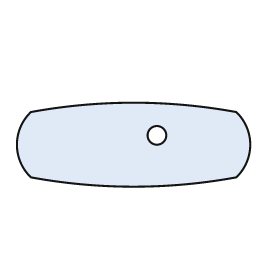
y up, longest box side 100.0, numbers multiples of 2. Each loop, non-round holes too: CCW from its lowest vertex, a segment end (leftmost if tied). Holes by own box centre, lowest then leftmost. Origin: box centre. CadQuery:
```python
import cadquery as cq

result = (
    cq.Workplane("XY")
    .moveTo(-44.0, -14.0)
    .threePointArc((0.0, -18.0), (44.0, -14.0))
    .threePointArc((50.0, 0.0), (44.0, 14.0))
    .threePointArc((0.0, 18.0), (-44.0, 14.0))
    .threePointArc((-50.0, 0.0), (-44.0, -14.0))
    .close()
    .moveTo(10.0, 4.0)
    .circle(4.0)
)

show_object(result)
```